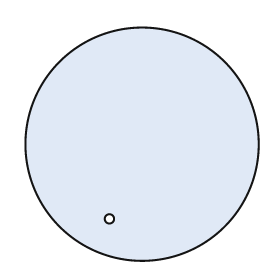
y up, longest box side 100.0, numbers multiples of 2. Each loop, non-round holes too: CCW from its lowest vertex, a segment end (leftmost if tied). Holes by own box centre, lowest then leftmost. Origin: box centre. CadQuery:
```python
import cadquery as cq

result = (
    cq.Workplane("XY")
    .moveTo(0.0, 0.0)
    .circle(50.0)
    .moveTo(-14.0, -32.0)
    .circle(2.0)
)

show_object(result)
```